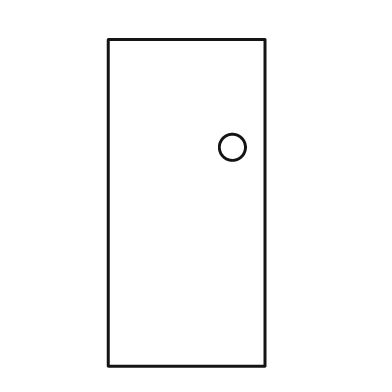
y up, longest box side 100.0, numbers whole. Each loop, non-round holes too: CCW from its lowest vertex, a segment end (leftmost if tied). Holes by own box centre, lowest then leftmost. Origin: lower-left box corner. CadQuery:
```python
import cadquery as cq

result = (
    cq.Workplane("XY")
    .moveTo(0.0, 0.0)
    .lineTo(48.0, 0.0)
    .lineTo(48.0, 100.0)
    .lineTo(0.0, 100.0)
    .close()
    .moveTo(38.0, 67.0)
    .circle(4.0)
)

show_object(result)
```